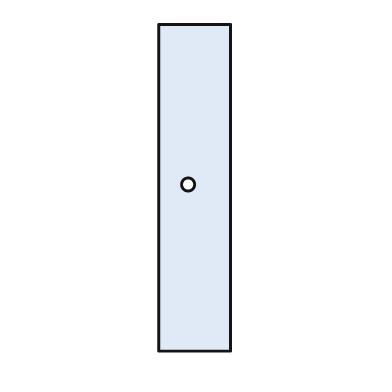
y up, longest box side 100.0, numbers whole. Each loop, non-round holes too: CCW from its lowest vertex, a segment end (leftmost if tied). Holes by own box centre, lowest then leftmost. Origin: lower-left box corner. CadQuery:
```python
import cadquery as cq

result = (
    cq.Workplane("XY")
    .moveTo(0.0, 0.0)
    .lineTo(22.0, 0.0)
    .lineTo(22.0, 100.0)
    .lineTo(0.0, 100.0)
    .close()
    .moveTo(9.0, 51.0)
    .circle(2.0)
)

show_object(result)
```